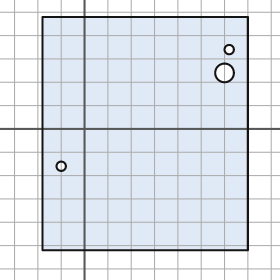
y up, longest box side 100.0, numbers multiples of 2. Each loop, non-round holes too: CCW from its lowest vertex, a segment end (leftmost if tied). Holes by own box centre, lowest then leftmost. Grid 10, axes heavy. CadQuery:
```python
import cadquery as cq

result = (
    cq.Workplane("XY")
    .moveTo(-18.0, -52.0)
    .lineTo(70.0, -52.0)
    .lineTo(70.0, 48.0)
    .lineTo(-18.0, 48.0)
    .close()
    .moveTo(-10.0, -16.0)
    .circle(2.0)
    .moveTo(60.0, 24.0)
    .circle(4.0)
    .moveTo(62.0, 34.0)
    .circle(2.0)
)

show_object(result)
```